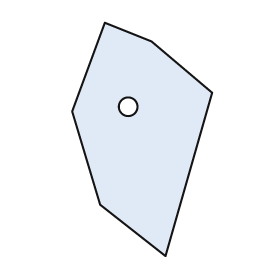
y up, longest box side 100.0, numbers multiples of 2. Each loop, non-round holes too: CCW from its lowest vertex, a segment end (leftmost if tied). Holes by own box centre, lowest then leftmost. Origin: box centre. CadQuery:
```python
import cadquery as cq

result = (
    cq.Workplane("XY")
    .moveTo(10.0, -50.0)
    .lineTo(30.0, 20.0)
    .lineTo(4.0, 42.0)
    .lineTo(-16.0, 50.0)
    .lineTo(-30.0, 12.0)
    .lineTo(-18.0, -28.0)
    .close()
    .moveTo(-6.0, 14.0)
    .circle(4.0)
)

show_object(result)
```